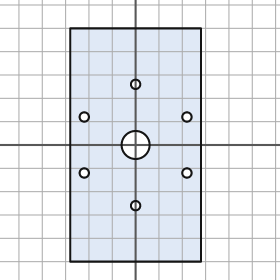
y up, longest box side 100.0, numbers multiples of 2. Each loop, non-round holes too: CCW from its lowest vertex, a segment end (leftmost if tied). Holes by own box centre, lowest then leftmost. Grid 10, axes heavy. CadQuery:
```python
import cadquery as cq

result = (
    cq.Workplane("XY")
    .moveTo(-28.0, -50.0)
    .lineTo(28.0, -50.0)
    .lineTo(28.0, 50.0)
    .lineTo(-28.0, 50.0)
    .close()
    .moveTo(0.0, -26.0)
    .circle(2.0)
    .moveTo(-22.0, -12.0)
    .circle(2.0)
    .moveTo(22.0, -12.0)
    .circle(2.0)
    .moveTo(0.0, 0.0)
    .circle(6.0)
    .moveTo(-22.0, 12.0)
    .circle(2.0)
    .moveTo(22.0, 12.0)
    .circle(2.0)
    .moveTo(0.0, 26.0)
    .circle(2.0)
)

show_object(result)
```